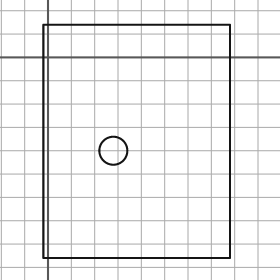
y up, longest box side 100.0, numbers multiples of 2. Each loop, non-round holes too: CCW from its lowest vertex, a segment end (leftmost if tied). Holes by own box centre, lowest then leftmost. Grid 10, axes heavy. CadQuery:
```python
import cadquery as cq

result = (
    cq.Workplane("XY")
    .moveTo(-2.0, -86.0)
    .lineTo(78.0, -86.0)
    .lineTo(78.0, 14.0)
    .lineTo(-2.0, 14.0)
    .close()
    .moveTo(28.0, -40.0)
    .circle(6.0)
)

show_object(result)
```